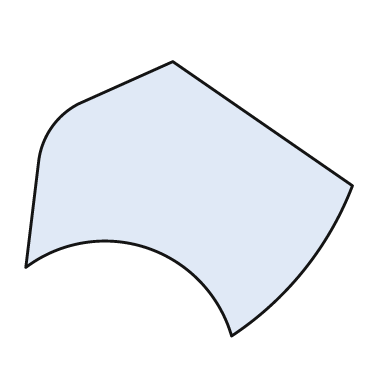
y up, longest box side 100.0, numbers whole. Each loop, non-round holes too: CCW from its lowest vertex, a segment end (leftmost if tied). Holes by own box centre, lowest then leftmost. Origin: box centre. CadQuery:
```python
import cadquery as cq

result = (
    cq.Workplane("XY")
    .moveTo(13.0, -42.0)
    .threePointArc((35.0, -22.0), (50.0, 4.0))
    .lineTo(-5.0, 42.0)
    .lineTo(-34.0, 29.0)
    .threePointArc((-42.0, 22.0), (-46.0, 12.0))
    .lineTo(-50.0, -21.0)
    .threePointArc((-13.0, -15.0), (13.0, -42.0))
    .close()
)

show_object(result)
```